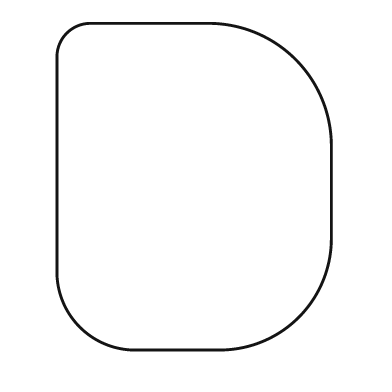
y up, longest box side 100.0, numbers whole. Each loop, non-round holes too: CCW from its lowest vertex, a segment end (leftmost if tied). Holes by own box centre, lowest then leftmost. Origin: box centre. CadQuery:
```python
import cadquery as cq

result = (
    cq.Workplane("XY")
    .moveTo(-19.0, -50.0)
    .lineTo(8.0, -50.0)
    .threePointArc((32.0, -40.0), (42.0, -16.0))
    .lineTo(42.0, 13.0)
    .threePointArc((31.0, 39.0), (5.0, 50.0))
    .lineTo(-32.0, 50.0)
    .threePointArc((-39.0, 47.0), (-42.0, 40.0))
    .lineTo(-42.0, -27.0)
    .threePointArc((-35.0, -43.0), (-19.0, -50.0))
    .close()
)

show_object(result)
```